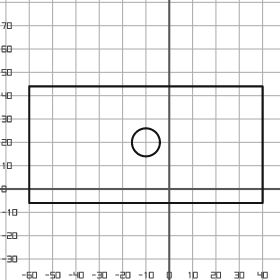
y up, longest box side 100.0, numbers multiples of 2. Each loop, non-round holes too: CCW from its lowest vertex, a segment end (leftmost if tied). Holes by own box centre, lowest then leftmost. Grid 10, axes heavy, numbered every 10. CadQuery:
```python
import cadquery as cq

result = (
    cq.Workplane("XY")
    .moveTo(-60.0, -6.0)
    .lineTo(40.0, -6.0)
    .lineTo(40.0, 44.0)
    .lineTo(-60.0, 44.0)
    .close()
    .moveTo(-10.0, 20.0)
    .circle(6.0)
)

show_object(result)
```